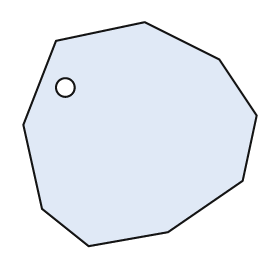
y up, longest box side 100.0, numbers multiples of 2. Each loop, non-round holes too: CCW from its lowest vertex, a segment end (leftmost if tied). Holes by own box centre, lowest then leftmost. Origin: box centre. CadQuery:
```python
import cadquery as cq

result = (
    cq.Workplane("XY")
    .moveTo(-22.0, -48.0)
    .lineTo(12.0, -42.0)
    .lineTo(44.0, -20.0)
    .lineTo(50.0, 8.0)
    .lineTo(34.0, 32.0)
    .lineTo(2.0, 48.0)
    .lineTo(-36.0, 40.0)
    .lineTo(-50.0, 4.0)
    .lineTo(-42.0, -32.0)
    .close()
    .moveTo(-32.0, 20.0)
    .circle(4.0)
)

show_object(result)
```